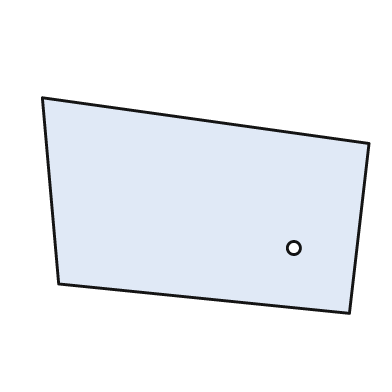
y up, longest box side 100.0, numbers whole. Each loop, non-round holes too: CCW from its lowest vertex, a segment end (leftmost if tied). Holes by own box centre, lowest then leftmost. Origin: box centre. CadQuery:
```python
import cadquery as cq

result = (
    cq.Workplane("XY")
    .moveTo(44.0, -33.0)
    .lineTo(50.0, 19.0)
    .lineTo(-50.0, 33.0)
    .lineTo(-45.0, -24.0)
    .close()
    .moveTo(27.0, -13.0)
    .circle(2.0)
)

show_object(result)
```